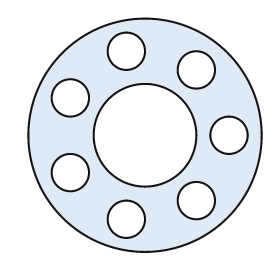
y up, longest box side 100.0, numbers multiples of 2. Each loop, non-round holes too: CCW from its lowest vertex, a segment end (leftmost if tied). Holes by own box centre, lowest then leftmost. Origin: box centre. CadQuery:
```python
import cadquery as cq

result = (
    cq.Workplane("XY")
    .moveTo(0.0, 0.0)
    .circle(50.0)
    .moveTo(-8.0, -36.0)
    .circle(8.0)
    .moveTo(22.0, -28.0)
    .circle(8.0)
    .moveTo(-32.0, -16.0)
    .circle(8.0)
    .moveTo(0.0, 0.0)
    .circle(22.0)
    .moveTo(36.0, 0.0)
    .circle(8.0)
    .moveTo(-32.0, 16.0)
    .circle(8.0)
    .moveTo(22.0, 28.0)
    .circle(8.0)
    .moveTo(-8.0, 36.0)
    .circle(8.0)
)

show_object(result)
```